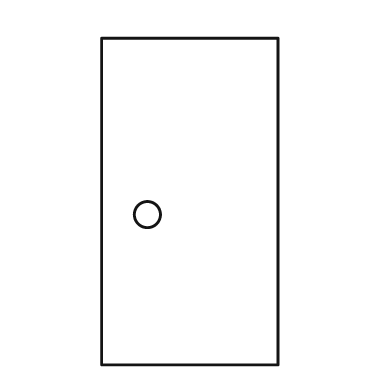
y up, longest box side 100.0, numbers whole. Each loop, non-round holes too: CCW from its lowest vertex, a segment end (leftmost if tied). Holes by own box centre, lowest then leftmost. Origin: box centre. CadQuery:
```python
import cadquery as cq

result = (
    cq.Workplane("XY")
    .moveTo(-27.0, -50.0)
    .lineTo(27.0, -50.0)
    .lineTo(27.0, 50.0)
    .lineTo(-27.0, 50.0)
    .close()
    .moveTo(-13.0, -4.0)
    .circle(4.0)
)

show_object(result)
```